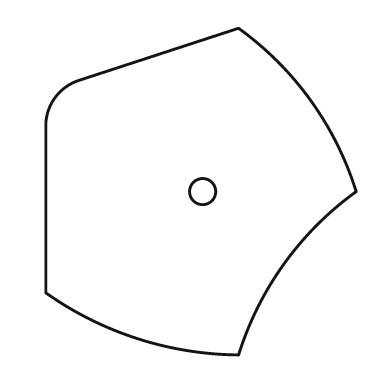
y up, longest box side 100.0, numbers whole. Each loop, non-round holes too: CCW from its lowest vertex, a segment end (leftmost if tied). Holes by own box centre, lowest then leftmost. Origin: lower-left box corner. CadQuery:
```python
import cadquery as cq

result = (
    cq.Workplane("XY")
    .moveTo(59.0, 0.0)
    .threePointArc((73.0, 28.0), (95.0, 50.0))
    .threePointArc((81.0, 78.0), (59.0, 100.0))
    .lineTo(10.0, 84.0)
    .threePointArc((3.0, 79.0), (0.0, 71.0))
    .lineTo(0.0, 19.0)
    .threePointArc((28.0, 5.0), (59.0, 0.0))
    .close()
    .moveTo(48.0, 50.0)
    .circle(4.0)
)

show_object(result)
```